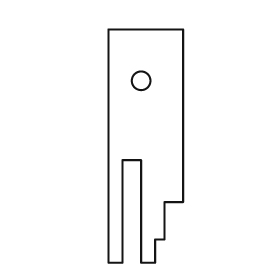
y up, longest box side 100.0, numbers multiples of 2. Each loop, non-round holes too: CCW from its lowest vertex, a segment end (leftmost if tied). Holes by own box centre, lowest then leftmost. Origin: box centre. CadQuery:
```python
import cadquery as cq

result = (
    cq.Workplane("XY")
    .moveTo(-16.0, -50.0)
    .lineTo(-10.0, -50.0)
    .lineTo(-10.0, -6.0)
    .lineTo(-2.0, -6.0)
    .lineTo(-2.0, -50.0)
    .lineTo(4.0, -50.0)
    .lineTo(4.0, -40.0)
    .lineTo(8.0, -40.0)
    .lineTo(8.0, -24.0)
    .lineTo(16.0, -24.0)
    .lineTo(16.0, 50.0)
    .lineTo(-16.0, 50.0)
    .close()
    .moveTo(-2.0, 28.0)
    .circle(4.0)
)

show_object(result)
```